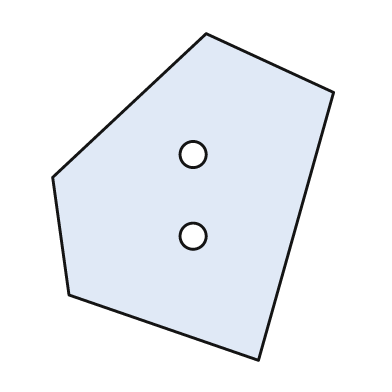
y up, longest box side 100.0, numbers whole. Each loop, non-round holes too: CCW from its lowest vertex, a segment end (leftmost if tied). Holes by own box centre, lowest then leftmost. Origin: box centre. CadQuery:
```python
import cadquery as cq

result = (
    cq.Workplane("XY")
    .moveTo(20.0, -50.0)
    .lineTo(43.0, 32.0)
    .lineTo(4.0, 50.0)
    .lineTo(-43.0, 6.0)
    .lineTo(-38.0, -30.0)
    .close()
    .moveTo(0.0, -12.0)
    .circle(4.0)
    .moveTo(0.0, 13.0)
    .circle(4.0)
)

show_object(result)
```